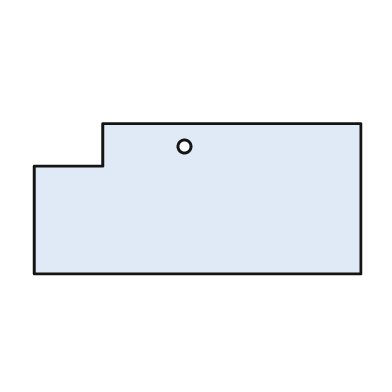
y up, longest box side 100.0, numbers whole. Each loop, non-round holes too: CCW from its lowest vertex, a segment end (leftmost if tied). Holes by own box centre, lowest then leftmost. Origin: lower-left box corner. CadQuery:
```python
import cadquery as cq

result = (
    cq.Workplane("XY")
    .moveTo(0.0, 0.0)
    .lineTo(100.0, 0.0)
    .lineTo(100.0, 46.0)
    .lineTo(21.0, 46.0)
    .lineTo(21.0, 33.0)
    .lineTo(0.0, 33.0)
    .close()
    .moveTo(46.0, 39.0)
    .circle(2.0)
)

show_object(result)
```